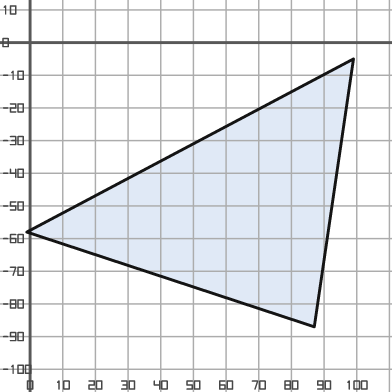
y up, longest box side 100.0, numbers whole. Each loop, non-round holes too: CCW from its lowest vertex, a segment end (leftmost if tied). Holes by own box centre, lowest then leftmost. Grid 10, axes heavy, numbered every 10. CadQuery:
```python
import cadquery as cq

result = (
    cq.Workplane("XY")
    .moveTo(87.0, -87.0)
    .lineTo(99.0, -5.0)
    .lineTo(-1.0, -58.0)
    .close()
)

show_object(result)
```